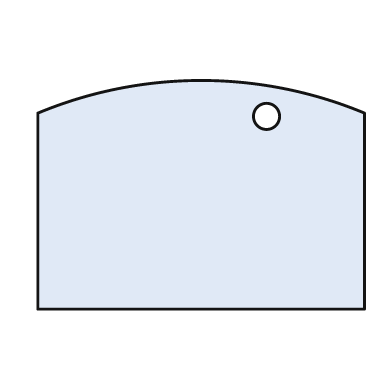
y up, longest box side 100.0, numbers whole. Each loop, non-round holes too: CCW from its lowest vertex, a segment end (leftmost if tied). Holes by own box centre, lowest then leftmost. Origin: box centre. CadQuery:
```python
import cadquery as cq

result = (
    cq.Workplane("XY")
    .moveTo(-50.0, -35.0)
    .lineTo(50.0, -35.0)
    .lineTo(50.0, 25.0)
    .threePointArc((0.0, 35.0), (-50.0, 25.0))
    .close()
    .moveTo(20.0, 24.0)
    .circle(4.0)
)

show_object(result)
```